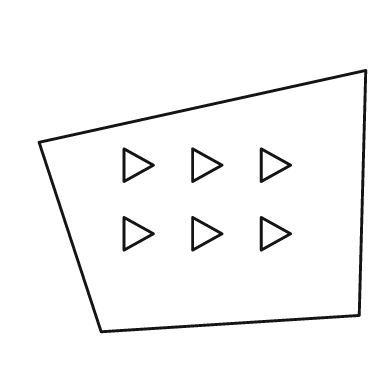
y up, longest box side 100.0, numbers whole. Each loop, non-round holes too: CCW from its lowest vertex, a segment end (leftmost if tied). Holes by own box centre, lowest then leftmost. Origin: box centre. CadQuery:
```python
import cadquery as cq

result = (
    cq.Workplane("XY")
    .moveTo(-31.0, -40.0)
    .lineTo(48.0, -35.0)
    .lineTo(50.0, 40.0)
    .lineTo(-50.0, 18.0)
    .close()
    .moveTo(-24.0, -15.0)
    .lineTo(-15.0, -10.0)
    .lineTo(-24.0, -5.0)
    .close()
    .moveTo(-3.0, -15.0)
    .lineTo(6.0, -10.0)
    .lineTo(-3.0, -5.0)
    .close()
    .moveTo(18.0, -15.0)
    .lineTo(27.0, -10.0)
    .lineTo(18.0, -5.0)
    .close()
    .moveTo(-24.0, 6.0)
    .lineTo(-15.0, 11.0)
    .lineTo(-24.0, 16.0)
    .close()
    .moveTo(-3.0, 6.0)
    .lineTo(6.0, 11.0)
    .lineTo(-3.0, 16.0)
    .close()
    .moveTo(18.0, 6.0)
    .lineTo(27.0, 11.0)
    .lineTo(18.0, 16.0)
    .close()
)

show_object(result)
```